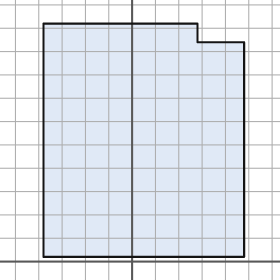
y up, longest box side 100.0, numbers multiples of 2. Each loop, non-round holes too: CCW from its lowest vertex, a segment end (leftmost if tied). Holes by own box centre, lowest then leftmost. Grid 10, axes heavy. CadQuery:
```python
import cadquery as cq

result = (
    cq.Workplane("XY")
    .moveTo(-38.0, 2.0)
    .lineTo(48.0, 2.0)
    .lineTo(48.0, 94.0)
    .lineTo(28.0, 94.0)
    .lineTo(28.0, 102.0)
    .lineTo(-38.0, 102.0)
    .close()
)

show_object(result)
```